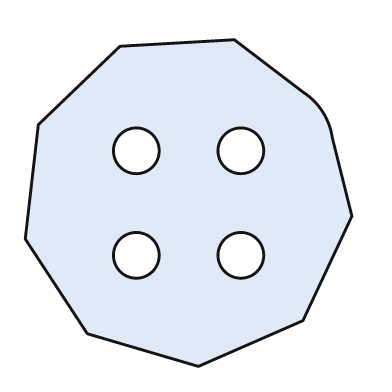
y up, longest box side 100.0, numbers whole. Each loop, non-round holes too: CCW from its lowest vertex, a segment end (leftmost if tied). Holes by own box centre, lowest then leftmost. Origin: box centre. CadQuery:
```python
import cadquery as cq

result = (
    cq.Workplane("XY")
    .moveTo(3.0, -50.0)
    .lineTo(35.0, -36.0)
    .lineTo(50.0, -4.0)
    .lineTo(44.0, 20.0)
    .threePointArc((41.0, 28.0), (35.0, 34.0))
    .lineTo(14.0, 50.0)
    .lineTo(-21.0, 48.0)
    .lineTo(-46.0, 24.0)
    .lineTo(-50.0, -11.0)
    .lineTo(-31.0, -40.0)
    .close()
    .moveTo(-16.0, -16.0)
    .circle(7.0)
    .moveTo(16.0, -16.0)
    .circle(7.0)
    .moveTo(-16.0, 16.0)
    .circle(7.0)
    .moveTo(16.0, 16.0)
    .circle(7.0)
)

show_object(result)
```